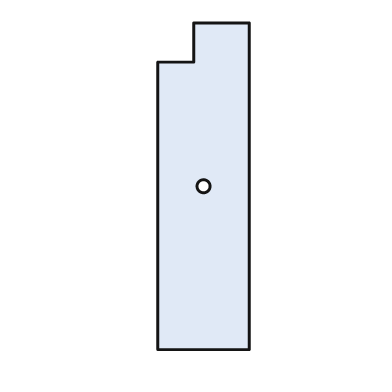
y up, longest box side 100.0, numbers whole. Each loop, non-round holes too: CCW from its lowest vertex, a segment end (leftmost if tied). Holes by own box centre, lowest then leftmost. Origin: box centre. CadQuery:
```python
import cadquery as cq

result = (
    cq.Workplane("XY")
    .moveTo(-14.0, -50.0)
    .lineTo(14.0, -50.0)
    .lineTo(14.0, 50.0)
    .lineTo(-3.0, 50.0)
    .lineTo(-3.0, 38.0)
    .lineTo(-14.0, 38.0)
    .close()
    .moveTo(0.0, 0.0)
    .circle(2.0)
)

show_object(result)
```